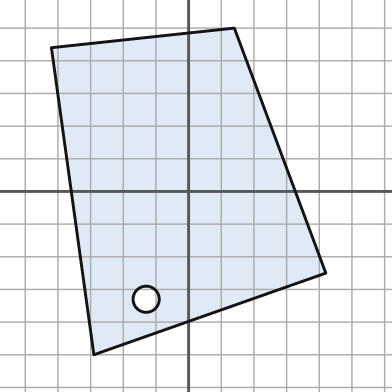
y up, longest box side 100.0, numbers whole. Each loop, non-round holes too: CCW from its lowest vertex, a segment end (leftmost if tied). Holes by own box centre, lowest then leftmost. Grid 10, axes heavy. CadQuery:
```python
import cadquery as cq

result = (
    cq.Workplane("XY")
    .moveTo(-29.0, -50.0)
    .lineTo(42.0, -25.0)
    .lineTo(14.0, 50.0)
    .lineTo(-42.0, 44.0)
    .close()
    .moveTo(-13.0, -33.0)
    .circle(4.0)
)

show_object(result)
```